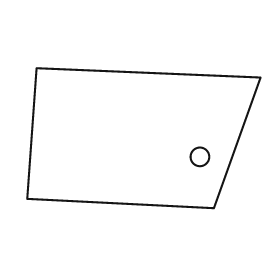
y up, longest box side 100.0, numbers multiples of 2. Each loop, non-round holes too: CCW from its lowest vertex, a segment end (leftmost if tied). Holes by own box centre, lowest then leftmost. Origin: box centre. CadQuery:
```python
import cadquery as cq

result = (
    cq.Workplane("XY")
    .moveTo(30.0, -30.0)
    .lineTo(50.0, 26.0)
    .lineTo(-46.0, 30.0)
    .lineTo(-50.0, -26.0)
    .close()
    .moveTo(24.0, -8.0)
    .circle(4.0)
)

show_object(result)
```